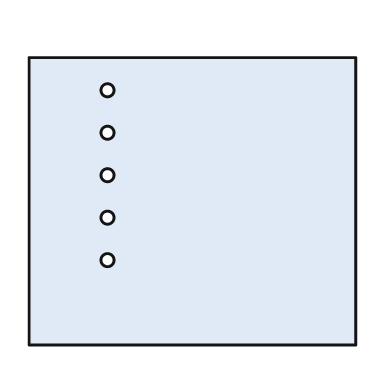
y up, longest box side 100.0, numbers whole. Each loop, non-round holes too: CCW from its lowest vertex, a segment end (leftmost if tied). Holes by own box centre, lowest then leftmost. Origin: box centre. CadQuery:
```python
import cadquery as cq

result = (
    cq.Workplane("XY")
    .moveTo(-50.0, -44.0)
    .lineTo(50.0, -44.0)
    .lineTo(50.0, 44.0)
    .lineTo(-50.0, 44.0)
    .close()
    .moveTo(-26.0, -18.0)
    .circle(2.0)
    .moveTo(-26.0, -5.0)
    .circle(2.0)
    .moveTo(-26.0, 8.0)
    .circle(2.0)
    .moveTo(-26.0, 21.0)
    .circle(2.0)
    .moveTo(-26.0, 34.0)
    .circle(2.0)
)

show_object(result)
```